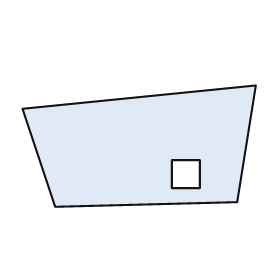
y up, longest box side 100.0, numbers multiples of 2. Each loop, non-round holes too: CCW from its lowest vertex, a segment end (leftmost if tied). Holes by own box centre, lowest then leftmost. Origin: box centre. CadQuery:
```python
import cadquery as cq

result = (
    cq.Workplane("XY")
    .moveTo(-36.0, -26.0)
    .lineTo(42.0, -24.0)
    .lineTo(50.0, 26.0)
    .lineTo(-50.0, 16.0)
    .close()
    .moveTo(14.0, -18.0)
    .lineTo(26.0, -18.0)
    .lineTo(26.0, -6.0)
    .lineTo(14.0, -6.0)
    .close()
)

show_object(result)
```